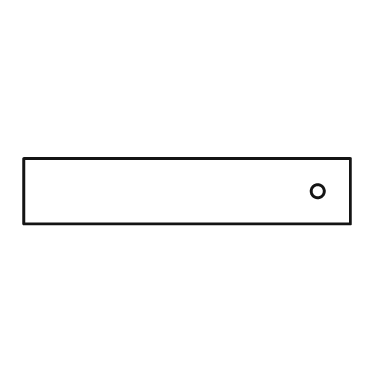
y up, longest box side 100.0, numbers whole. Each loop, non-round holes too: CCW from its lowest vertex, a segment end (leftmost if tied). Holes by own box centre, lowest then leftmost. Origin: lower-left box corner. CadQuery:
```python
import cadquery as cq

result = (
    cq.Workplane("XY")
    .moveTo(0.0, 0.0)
    .lineTo(100.0, 0.0)
    .lineTo(100.0, 20.0)
    .lineTo(0.0, 20.0)
    .close()
    .moveTo(90.0, 10.0)
    .circle(2.0)
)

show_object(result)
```